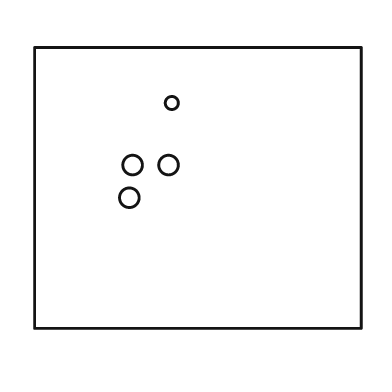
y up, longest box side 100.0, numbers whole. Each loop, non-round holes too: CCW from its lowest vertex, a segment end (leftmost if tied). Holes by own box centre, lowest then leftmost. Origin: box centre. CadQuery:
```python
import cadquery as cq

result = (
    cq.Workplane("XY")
    .moveTo(-50.0, -43.0)
    .lineTo(50.0, -43.0)
    .lineTo(50.0, 43.0)
    .lineTo(-50.0, 43.0)
    .close()
    .moveTo(-21.0, -3.0)
    .circle(3.0)
    .moveTo(-20.0, 7.0)
    .circle(3.0)
    .moveTo(-9.0, 7.0)
    .circle(3.0)
    .moveTo(-8.0, 26.0)
    .circle(2.0)
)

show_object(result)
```